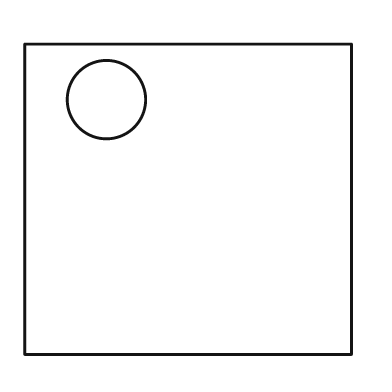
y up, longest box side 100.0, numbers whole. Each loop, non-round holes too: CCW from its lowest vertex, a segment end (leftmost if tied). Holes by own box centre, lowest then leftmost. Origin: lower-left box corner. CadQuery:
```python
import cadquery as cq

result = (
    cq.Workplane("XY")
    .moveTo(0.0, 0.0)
    .lineTo(100.0, 0.0)
    .lineTo(100.0, 95.0)
    .lineTo(0.0, 95.0)
    .close()
    .moveTo(25.0, 78.0)
    .circle(12.0)
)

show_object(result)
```